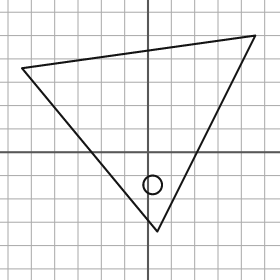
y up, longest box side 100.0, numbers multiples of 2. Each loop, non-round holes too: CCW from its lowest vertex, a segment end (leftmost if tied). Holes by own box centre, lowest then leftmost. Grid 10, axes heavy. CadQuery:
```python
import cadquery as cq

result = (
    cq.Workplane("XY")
    .moveTo(4.0, -34.0)
    .lineTo(46.0, 50.0)
    .lineTo(-54.0, 36.0)
    .close()
    .moveTo(2.0, -14.0)
    .circle(4.0)
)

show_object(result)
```